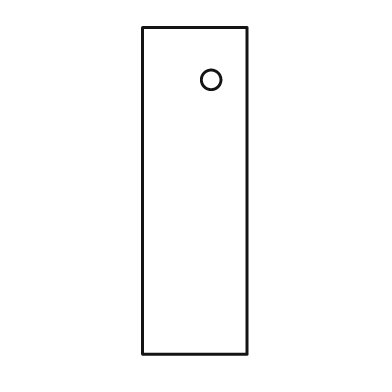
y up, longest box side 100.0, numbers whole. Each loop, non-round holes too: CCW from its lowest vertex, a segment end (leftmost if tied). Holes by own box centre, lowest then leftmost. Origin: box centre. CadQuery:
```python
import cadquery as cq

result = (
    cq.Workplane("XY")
    .moveTo(-16.0, -50.0)
    .lineTo(16.0, -50.0)
    .lineTo(16.0, 50.0)
    .lineTo(-16.0, 50.0)
    .close()
    .moveTo(5.0, 34.0)
    .circle(3.0)
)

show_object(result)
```